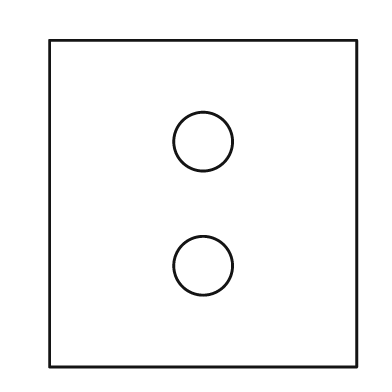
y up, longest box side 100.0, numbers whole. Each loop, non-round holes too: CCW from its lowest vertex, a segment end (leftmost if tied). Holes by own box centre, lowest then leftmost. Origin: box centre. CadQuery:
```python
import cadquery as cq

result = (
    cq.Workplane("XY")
    .moveTo(-47.0, -50.0)
    .lineTo(47.0, -50.0)
    .lineTo(47.0, 50.0)
    .lineTo(-47.0, 50.0)
    .close()
    .moveTo(0.0, -19.0)
    .circle(9.0)
    .moveTo(0.0, 19.0)
    .circle(9.0)
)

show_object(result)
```